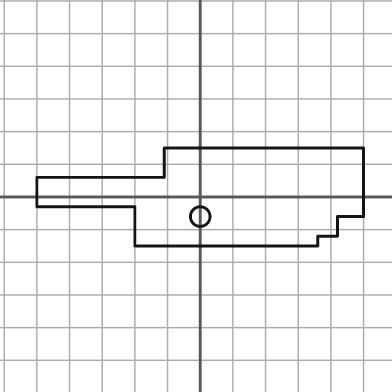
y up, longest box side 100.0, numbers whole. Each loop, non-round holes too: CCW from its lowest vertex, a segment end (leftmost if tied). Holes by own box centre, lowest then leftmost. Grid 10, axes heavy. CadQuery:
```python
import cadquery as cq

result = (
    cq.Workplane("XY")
    .moveTo(-20.0, -15.0)
    .lineTo(36.0, -15.0)
    .lineTo(36.0, -12.0)
    .lineTo(42.0, -12.0)
    .lineTo(42.0, -6.0)
    .lineTo(50.0, -6.0)
    .lineTo(50.0, 15.0)
    .lineTo(-11.0, 15.0)
    .lineTo(-11.0, 6.0)
    .lineTo(-50.0, 6.0)
    .lineTo(-50.0, -3.0)
    .lineTo(-20.0, -3.0)
    .close()
    .moveTo(0.0, -6.0)
    .circle(3.0)
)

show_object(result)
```